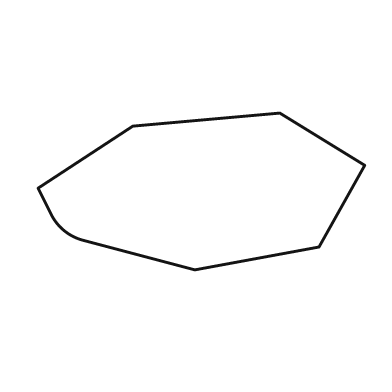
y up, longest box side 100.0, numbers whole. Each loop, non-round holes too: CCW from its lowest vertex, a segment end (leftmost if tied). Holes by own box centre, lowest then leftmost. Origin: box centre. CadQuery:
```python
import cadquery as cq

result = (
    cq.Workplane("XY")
    .moveTo(-2.0, -24.0)
    .lineTo(36.0, -17.0)
    .lineTo(50.0, 8.0)
    .lineTo(24.0, 24.0)
    .lineTo(-21.0, 20.0)
    .lineTo(-50.0, 1.0)
    .lineTo(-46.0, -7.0)
    .threePointArc((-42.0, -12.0), (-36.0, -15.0))
    .close()
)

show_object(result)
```